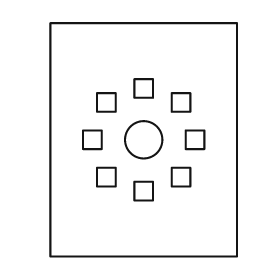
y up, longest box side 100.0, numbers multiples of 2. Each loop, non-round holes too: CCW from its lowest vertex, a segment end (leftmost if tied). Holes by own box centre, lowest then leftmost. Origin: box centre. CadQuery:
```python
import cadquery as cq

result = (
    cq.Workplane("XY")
    .moveTo(-40.0, -50.0)
    .lineTo(40.0, -50.0)
    .lineTo(40.0, 50.0)
    .lineTo(-40.0, 50.0)
    .close()
    .moveTo(-4.0, -26.0)
    .lineTo(4.0, -26.0)
    .lineTo(4.0, -18.0)
    .lineTo(-4.0, -18.0)
    .close()
    .moveTo(-20.0, -20.0)
    .lineTo(-12.0, -20.0)
    .lineTo(-12.0, -12.0)
    .lineTo(-20.0, -12.0)
    .close()
    .moveTo(12.0, -20.0)
    .lineTo(20.0, -20.0)
    .lineTo(20.0, -12.0)
    .lineTo(12.0, -12.0)
    .close()
    .moveTo(-26.0, -4.0)
    .lineTo(-18.0, -4.0)
    .lineTo(-18.0, 4.0)
    .lineTo(-26.0, 4.0)
    .close()
    .moveTo(0.0, 0.0)
    .circle(8.0)
    .moveTo(18.0, -4.0)
    .lineTo(26.0, -4.0)
    .lineTo(26.0, 4.0)
    .lineTo(18.0, 4.0)
    .close()
    .moveTo(-20.0, 12.0)
    .lineTo(-12.0, 12.0)
    .lineTo(-12.0, 20.0)
    .lineTo(-20.0, 20.0)
    .close()
    .moveTo(12.0, 12.0)
    .lineTo(20.0, 12.0)
    .lineTo(20.0, 20.0)
    .lineTo(12.0, 20.0)
    .close()
    .moveTo(-4.0, 18.0)
    .lineTo(4.0, 18.0)
    .lineTo(4.0, 26.0)
    .lineTo(-4.0, 26.0)
    .close()
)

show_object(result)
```